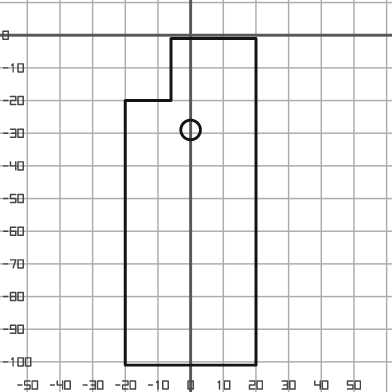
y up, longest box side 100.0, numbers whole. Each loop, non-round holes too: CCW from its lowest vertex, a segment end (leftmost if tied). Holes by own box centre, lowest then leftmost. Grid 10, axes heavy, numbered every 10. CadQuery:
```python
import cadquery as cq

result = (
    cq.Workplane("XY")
    .moveTo(-20.0, -101.0)
    .lineTo(20.0, -101.0)
    .lineTo(20.0, -1.0)
    .lineTo(-6.0, -1.0)
    .lineTo(-6.0, -20.0)
    .lineTo(-20.0, -20.0)
    .close()
    .moveTo(0.0, -29.0)
    .circle(3.0)
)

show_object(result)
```